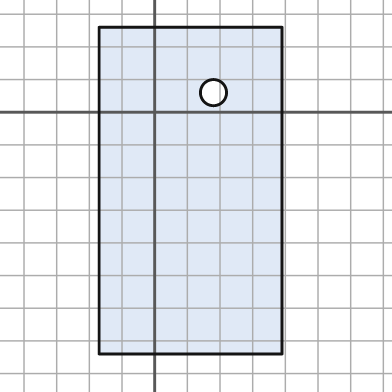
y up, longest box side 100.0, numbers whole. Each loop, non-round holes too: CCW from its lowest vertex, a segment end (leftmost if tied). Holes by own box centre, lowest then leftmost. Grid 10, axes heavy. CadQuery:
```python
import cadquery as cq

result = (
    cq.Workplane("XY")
    .moveTo(-17.0, -74.0)
    .lineTo(39.0, -74.0)
    .lineTo(39.0, 26.0)
    .lineTo(-17.0, 26.0)
    .close()
    .moveTo(18.0, 6.0)
    .circle(4.0)
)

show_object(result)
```